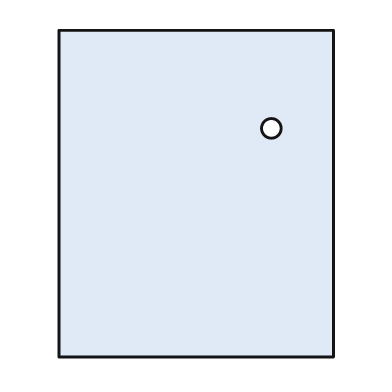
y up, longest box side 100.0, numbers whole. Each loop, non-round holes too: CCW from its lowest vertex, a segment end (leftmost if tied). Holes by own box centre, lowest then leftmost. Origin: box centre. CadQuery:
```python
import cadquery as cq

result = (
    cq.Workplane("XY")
    .moveTo(-42.0, -50.0)
    .lineTo(42.0, -50.0)
    .lineTo(42.0, 50.0)
    .lineTo(-42.0, 50.0)
    .close()
    .moveTo(23.0, 20.0)
    .circle(3.0)
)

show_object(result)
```